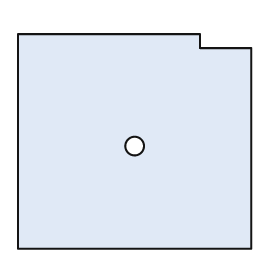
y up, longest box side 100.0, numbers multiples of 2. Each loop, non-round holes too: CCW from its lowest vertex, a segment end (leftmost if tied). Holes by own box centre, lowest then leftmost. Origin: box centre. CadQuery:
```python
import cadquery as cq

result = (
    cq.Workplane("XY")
    .moveTo(-50.0, -46.0)
    .lineTo(50.0, -46.0)
    .lineTo(50.0, 40.0)
    .lineTo(28.0, 40.0)
    .lineTo(28.0, 46.0)
    .lineTo(-50.0, 46.0)
    .close()
    .moveTo(0.0, -2.0)
    .circle(4.0)
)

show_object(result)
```